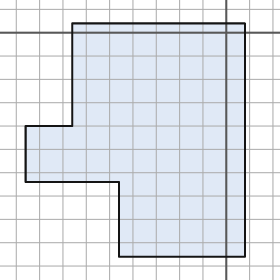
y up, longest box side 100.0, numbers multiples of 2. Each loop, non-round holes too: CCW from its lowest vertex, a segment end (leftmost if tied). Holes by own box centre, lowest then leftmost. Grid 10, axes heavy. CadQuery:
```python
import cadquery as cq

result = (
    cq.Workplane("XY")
    .moveTo(-46.0, -96.0)
    .lineTo(8.0, -96.0)
    .lineTo(8.0, 4.0)
    .lineTo(-66.0, 4.0)
    .lineTo(-66.0, -40.0)
    .lineTo(-86.0, -40.0)
    .lineTo(-86.0, -64.0)
    .lineTo(-46.0, -64.0)
    .close()
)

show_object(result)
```